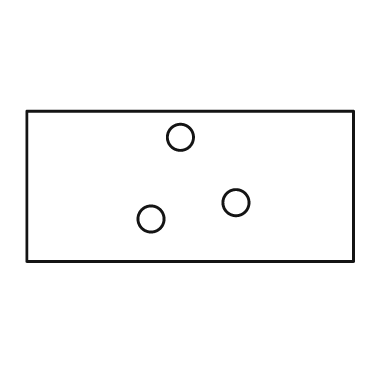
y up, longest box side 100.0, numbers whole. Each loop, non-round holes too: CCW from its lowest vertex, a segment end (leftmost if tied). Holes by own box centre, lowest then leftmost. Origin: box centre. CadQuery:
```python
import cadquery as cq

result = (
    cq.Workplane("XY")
    .moveTo(-50.0, -23.0)
    .lineTo(50.0, -23.0)
    .lineTo(50.0, 23.0)
    .lineTo(-50.0, 23.0)
    .close()
    .moveTo(-12.0, -10.0)
    .circle(4.0)
    .moveTo(14.0, -5.0)
    .circle(4.0)
    .moveTo(-3.0, 15.0)
    .circle(4.0)
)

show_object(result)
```